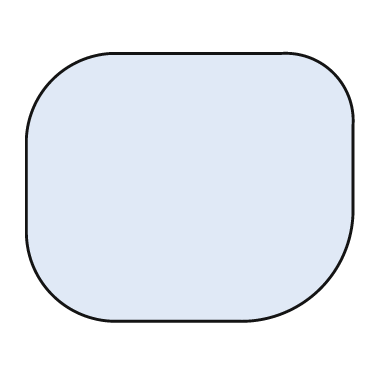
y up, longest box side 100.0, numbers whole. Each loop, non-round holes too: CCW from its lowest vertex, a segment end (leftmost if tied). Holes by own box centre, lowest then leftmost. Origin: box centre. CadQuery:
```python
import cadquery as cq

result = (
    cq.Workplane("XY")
    .moveTo(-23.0, -41.0)
    .lineTo(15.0, -41.0)
    .threePointArc((40.0, -31.0), (50.0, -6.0))
    .lineTo(50.0, 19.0)
    .threePointArc((44.0, 35.0), (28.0, 41.0))
    .lineTo(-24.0, 41.0)
    .threePointArc((-42.0, 33.0), (-50.0, 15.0))
    .lineTo(-50.0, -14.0)
    .threePointArc((-42.0, -33.0), (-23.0, -41.0))
    .close()
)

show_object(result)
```